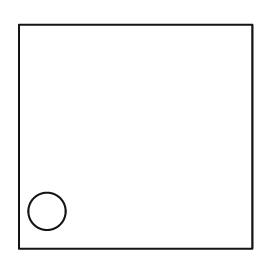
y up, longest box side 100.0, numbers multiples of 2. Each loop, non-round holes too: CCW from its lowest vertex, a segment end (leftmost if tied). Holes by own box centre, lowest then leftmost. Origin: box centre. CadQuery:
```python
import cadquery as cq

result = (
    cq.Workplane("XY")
    .moveTo(-50.0, -48.0)
    .lineTo(50.0, -48.0)
    .lineTo(50.0, 48.0)
    .lineTo(-50.0, 48.0)
    .close()
    .moveTo(-38.0, -32.0)
    .circle(8.0)
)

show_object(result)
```